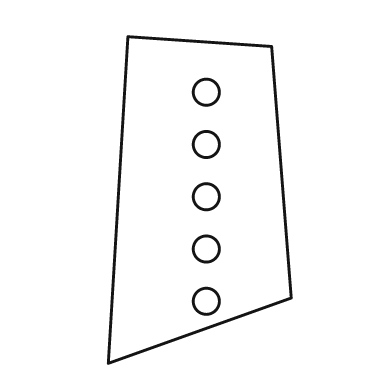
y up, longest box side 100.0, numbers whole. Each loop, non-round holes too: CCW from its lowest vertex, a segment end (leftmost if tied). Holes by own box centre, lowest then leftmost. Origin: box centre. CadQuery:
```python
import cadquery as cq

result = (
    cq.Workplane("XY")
    .moveTo(-28.0, -50.0)
    .lineTo(28.0, -30.0)
    .lineTo(22.0, 47.0)
    .lineTo(-22.0, 50.0)
    .close()
    .moveTo(2.0, -31.0)
    .circle(4.0)
    .moveTo(2.0, -15.0)
    .circle(4.0)
    .moveTo(2.0, 1.0)
    .circle(4.0)
    .moveTo(2.0, 17.0)
    .circle(4.0)
    .moveTo(2.0, 33.0)
    .circle(4.0)
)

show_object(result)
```